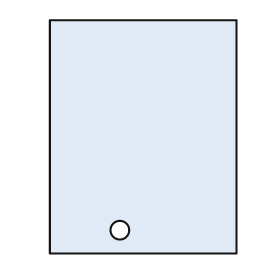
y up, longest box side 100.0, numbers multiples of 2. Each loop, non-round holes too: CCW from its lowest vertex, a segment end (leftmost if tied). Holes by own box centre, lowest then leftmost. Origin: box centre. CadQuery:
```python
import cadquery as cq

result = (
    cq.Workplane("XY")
    .moveTo(-40.0, -50.0)
    .lineTo(40.0, -50.0)
    .lineTo(40.0, 50.0)
    .lineTo(-40.0, 50.0)
    .close()
    .moveTo(-10.0, -40.0)
    .circle(4.0)
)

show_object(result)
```